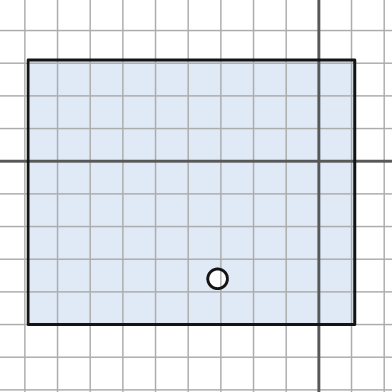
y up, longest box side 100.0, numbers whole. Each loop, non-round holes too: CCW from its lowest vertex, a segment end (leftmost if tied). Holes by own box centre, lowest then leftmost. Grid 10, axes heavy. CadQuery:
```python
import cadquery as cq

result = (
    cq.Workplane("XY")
    .moveTo(-89.0, -50.0)
    .lineTo(11.0, -50.0)
    .lineTo(11.0, 31.0)
    .lineTo(-89.0, 31.0)
    .close()
    .moveTo(-31.0, -36.0)
    .circle(3.0)
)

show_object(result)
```